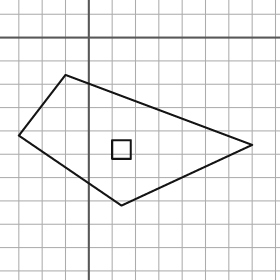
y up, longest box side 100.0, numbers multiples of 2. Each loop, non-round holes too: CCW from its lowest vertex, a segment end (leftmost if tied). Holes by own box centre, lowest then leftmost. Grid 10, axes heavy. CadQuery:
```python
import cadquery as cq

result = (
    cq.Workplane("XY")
    .moveTo(14.0, -72.0)
    .lineTo(70.0, -46.0)
    .lineTo(-10.0, -16.0)
    .lineTo(-30.0, -42.0)
    .close()
    .moveTo(10.0, -52.0)
    .lineTo(18.0, -52.0)
    .lineTo(18.0, -44.0)
    .lineTo(10.0, -44.0)
    .close()
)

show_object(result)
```